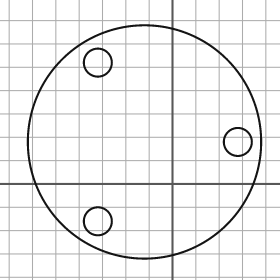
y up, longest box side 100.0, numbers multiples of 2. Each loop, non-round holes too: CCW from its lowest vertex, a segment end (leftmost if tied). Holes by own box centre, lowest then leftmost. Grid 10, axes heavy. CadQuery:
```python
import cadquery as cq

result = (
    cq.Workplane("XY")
    .moveTo(-12.0, 18.0)
    .circle(50.0)
    .moveTo(-32.0, -16.0)
    .circle(6.0)
    .moveTo(28.0, 18.0)
    .circle(6.0)
    .moveTo(-32.0, 52.0)
    .circle(6.0)
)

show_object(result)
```